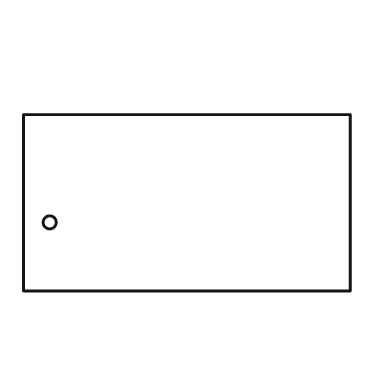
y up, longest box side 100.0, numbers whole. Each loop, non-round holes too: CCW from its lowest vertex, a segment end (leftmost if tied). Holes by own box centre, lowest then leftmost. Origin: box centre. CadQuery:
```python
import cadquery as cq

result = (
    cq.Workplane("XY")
    .moveTo(-50.0, -27.0)
    .lineTo(50.0, -27.0)
    .lineTo(50.0, 27.0)
    .lineTo(-50.0, 27.0)
    .close()
    .moveTo(-42.0, -6.0)
    .circle(2.0)
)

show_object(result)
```